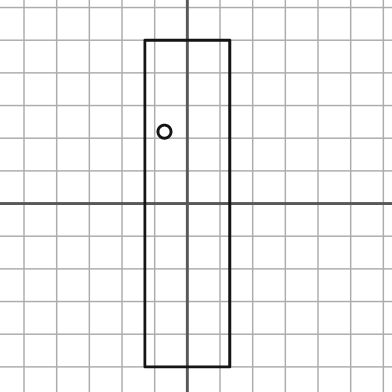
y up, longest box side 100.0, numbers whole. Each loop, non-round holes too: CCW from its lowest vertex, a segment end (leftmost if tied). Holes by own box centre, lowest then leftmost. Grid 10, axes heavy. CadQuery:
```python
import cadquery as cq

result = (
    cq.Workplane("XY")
    .moveTo(-13.0, -50.0)
    .lineTo(13.0, -50.0)
    .lineTo(13.0, 50.0)
    .lineTo(-13.0, 50.0)
    .close()
    .moveTo(-7.0, 22.0)
    .circle(2.0)
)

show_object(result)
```